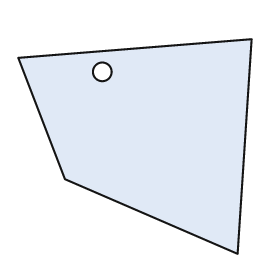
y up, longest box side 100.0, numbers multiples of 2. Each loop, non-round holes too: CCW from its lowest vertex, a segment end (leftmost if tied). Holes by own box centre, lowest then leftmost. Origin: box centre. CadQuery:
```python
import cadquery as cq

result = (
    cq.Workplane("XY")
    .moveTo(44.0, -46.0)
    .lineTo(50.0, 46.0)
    .lineTo(-50.0, 38.0)
    .lineTo(-30.0, -14.0)
    .close()
    .moveTo(-14.0, 32.0)
    .circle(4.0)
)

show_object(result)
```